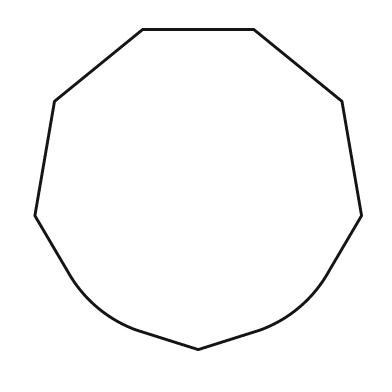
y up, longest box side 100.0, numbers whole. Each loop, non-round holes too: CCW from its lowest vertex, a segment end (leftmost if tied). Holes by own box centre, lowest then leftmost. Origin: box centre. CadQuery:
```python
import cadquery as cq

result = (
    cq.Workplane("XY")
    .moveTo(0.0, -49.0)
    .lineTo(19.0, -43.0)
    .threePointArc((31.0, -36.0), (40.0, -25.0))
    .lineTo(50.0, -8.0)
    .lineTo(44.0, 27.0)
    .lineTo(17.0, 49.0)
    .lineTo(-17.0, 49.0)
    .lineTo(-44.0, 27.0)
    .lineTo(-50.0, -8.0)
    .lineTo(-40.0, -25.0)
    .threePointArc((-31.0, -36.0), (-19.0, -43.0))
    .close()
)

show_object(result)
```